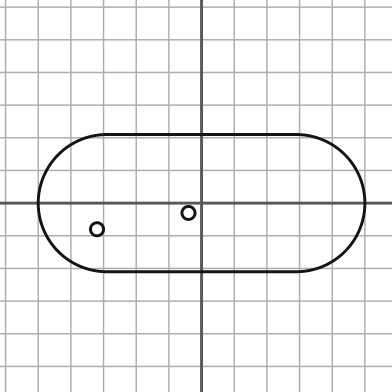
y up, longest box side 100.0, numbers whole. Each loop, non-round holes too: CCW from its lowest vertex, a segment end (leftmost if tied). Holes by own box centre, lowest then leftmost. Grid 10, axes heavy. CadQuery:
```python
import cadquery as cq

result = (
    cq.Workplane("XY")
    .moveTo(-29.0, -21.0)
    .lineTo(29.0, -21.0)
    .threePointArc((50.0, 0.0), (29.0, 21.0))
    .lineTo(-29.0, 21.0)
    .threePointArc((-50.0, 0.0), (-29.0, -21.0))
    .close()
    .moveTo(-32.0, -8.0)
    .circle(2.0)
    .moveTo(-4.0, -3.0)
    .circle(2.0)
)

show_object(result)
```